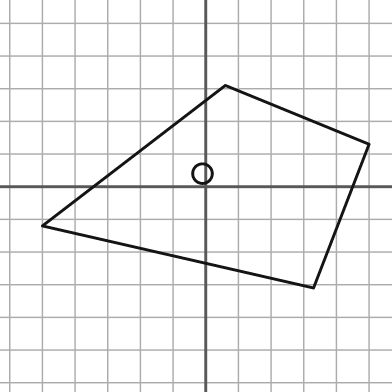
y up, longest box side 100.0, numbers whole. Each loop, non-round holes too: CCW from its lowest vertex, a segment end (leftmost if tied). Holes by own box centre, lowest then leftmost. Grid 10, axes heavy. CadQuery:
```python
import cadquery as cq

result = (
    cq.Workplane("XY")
    .moveTo(33.0, -31.0)
    .lineTo(50.0, 13.0)
    .lineTo(6.0, 31.0)
    .lineTo(-50.0, -12.0)
    .close()
    .moveTo(-1.0, 4.0)
    .circle(3.0)
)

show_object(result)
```